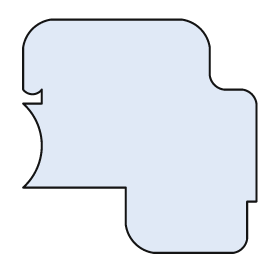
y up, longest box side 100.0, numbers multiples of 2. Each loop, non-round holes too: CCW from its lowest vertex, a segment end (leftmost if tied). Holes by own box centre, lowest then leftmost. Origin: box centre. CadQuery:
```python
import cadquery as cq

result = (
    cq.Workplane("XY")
    .moveTo(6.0, -50.0)
    .lineTo(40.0, -50.0)
    .threePointArc((44.0, -48.0), (46.0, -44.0))
    .lineTo(46.0, -28.0)
    .lineTo(50.0, -28.0)
    .lineTo(50.0, 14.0)
    .threePointArc((48.0, 18.0), (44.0, 20.0))
    .lineTo(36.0, 20.0)
    .threePointArc((32.0, 22.0), (30.0, 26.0))
    .lineTo(30.0, 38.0)
    .threePointArc((26.0, 46.0), (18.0, 50.0))
    .lineTo(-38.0, 50.0)
    .threePointArc((-46.0, 46.0), (-50.0, 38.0))
    .lineTo(-50.0, 20.0)
    .threePointArc((-46.0, 18.0), (-42.0, 20.0))
    .lineTo(-42.0, 14.0)
    .lineTo(-50.0, 14.0)
    .threePointArc((-42.0, -4.0), (-50.0, -22.0))
    .lineTo(-6.0, -22.0)
    .lineTo(-6.0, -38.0)
    .threePointArc((-2.0, -46.0), (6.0, -50.0))
    .close()
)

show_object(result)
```